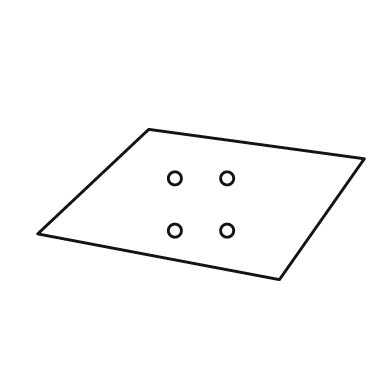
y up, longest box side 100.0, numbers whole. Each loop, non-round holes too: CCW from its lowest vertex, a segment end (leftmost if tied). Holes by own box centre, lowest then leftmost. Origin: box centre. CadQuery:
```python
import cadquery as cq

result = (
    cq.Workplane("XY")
    .moveTo(24.0, -23.0)
    .lineTo(50.0, 14.0)
    .lineTo(-16.0, 23.0)
    .lineTo(-50.0, -9.0)
    .close()
    .moveTo(-8.0, -8.0)
    .circle(2.0)
    .moveTo(8.0, -8.0)
    .circle(2.0)
    .moveTo(-8.0, 8.0)
    .circle(2.0)
    .moveTo(8.0, 8.0)
    .circle(2.0)
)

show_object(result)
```